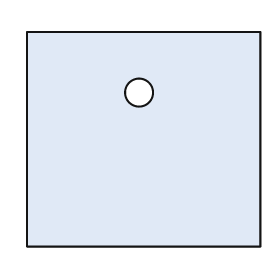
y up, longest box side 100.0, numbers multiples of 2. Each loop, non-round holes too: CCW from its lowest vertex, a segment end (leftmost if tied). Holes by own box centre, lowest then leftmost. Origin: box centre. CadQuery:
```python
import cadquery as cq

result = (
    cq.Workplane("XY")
    .moveTo(-50.0, -46.0)
    .lineTo(50.0, -46.0)
    .lineTo(50.0, 46.0)
    .lineTo(-50.0, 46.0)
    .close()
    .moveTo(-2.0, 20.0)
    .circle(6.0)
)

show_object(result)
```